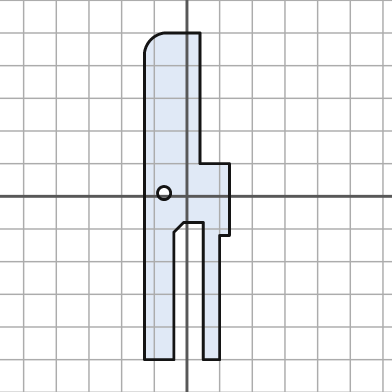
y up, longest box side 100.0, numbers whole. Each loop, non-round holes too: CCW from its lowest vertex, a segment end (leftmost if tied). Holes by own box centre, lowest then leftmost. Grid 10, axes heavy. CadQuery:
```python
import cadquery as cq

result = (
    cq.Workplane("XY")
    .moveTo(-13.0, -50.0)
    .lineTo(-4.0, -50.0)
    .lineTo(-4.0, -11.0)
    .lineTo(-1.0, -8.0)
    .lineTo(5.0, -8.0)
    .lineTo(5.0, -50.0)
    .lineTo(10.0, -50.0)
    .lineTo(10.0, -12.0)
    .lineTo(13.0, -12.0)
    .lineTo(13.0, 10.0)
    .lineTo(4.0, 10.0)
    .lineTo(4.0, 50.0)
    .lineTo(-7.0, 50.0)
    .threePointArc((-11.0, 48.0), (-13.0, 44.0))
    .close()
    .moveTo(-7.0, 1.0)
    .circle(2.0)
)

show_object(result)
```